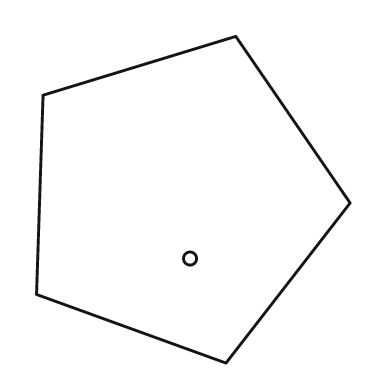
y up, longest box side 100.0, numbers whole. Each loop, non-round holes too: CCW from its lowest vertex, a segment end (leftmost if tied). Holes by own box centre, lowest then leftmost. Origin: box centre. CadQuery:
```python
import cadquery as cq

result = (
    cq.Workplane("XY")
    .moveTo(10.0, -50.0)
    .lineTo(48.0, -1.0)
    .lineTo(13.0, 50.0)
    .lineTo(-46.0, 32.0)
    .lineTo(-48.0, -29.0)
    .close()
    .moveTo(-1.0, -18.0)
    .circle(2.0)
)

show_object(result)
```